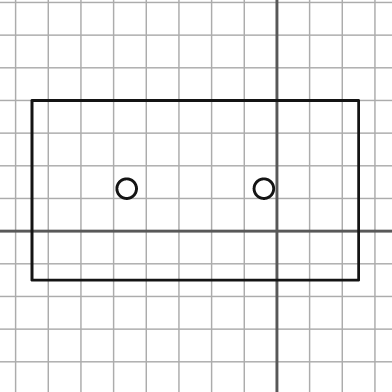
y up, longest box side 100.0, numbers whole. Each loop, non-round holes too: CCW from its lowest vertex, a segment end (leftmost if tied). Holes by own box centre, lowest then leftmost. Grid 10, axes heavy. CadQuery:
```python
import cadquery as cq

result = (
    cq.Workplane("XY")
    .moveTo(-75.0, -15.0)
    .lineTo(25.0, -15.0)
    .lineTo(25.0, 40.0)
    .lineTo(-75.0, 40.0)
    .close()
    .moveTo(-46.0, 13.0)
    .circle(3.0)
    .moveTo(-4.0, 13.0)
    .circle(3.0)
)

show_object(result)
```